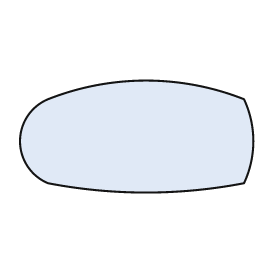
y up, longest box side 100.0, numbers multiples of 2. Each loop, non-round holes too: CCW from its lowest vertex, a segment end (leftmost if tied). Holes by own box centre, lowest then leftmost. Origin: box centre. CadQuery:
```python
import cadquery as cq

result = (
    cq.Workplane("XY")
    .moveTo(-38.0, -20.0)
    .threePointArc((4.0, -24.0), (46.0, -20.0))
    .threePointArc((50.0, -2.0), (46.0, 16.0))
    .threePointArc((4.0, 24.0), (-38.0, 16.0))
    .threePointArc((-50.0, -2.0), (-38.0, -20.0))
    .close()
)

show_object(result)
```